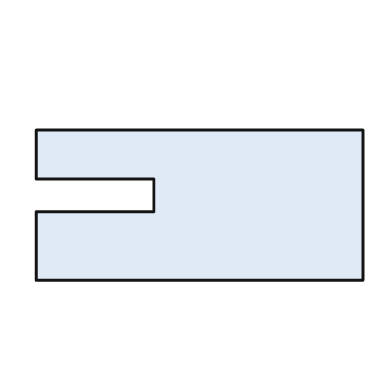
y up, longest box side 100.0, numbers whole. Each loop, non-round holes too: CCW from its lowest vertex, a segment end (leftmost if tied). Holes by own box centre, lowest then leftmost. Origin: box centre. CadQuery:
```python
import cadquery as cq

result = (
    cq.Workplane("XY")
    .moveTo(-50.0, -23.0)
    .lineTo(50.0, -23.0)
    .lineTo(50.0, 23.0)
    .lineTo(-50.0, 23.0)
    .lineTo(-50.0, 8.0)
    .lineTo(-14.0, 8.0)
    .lineTo(-14.0, -2.0)
    .lineTo(-50.0, -2.0)
    .close()
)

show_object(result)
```